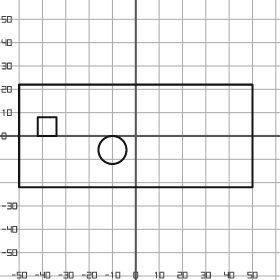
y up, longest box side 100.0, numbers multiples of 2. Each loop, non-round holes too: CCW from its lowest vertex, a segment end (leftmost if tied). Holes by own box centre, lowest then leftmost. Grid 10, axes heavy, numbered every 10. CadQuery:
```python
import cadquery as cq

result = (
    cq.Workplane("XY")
    .moveTo(-50.0, -22.0)
    .lineTo(50.0, -22.0)
    .lineTo(50.0, 22.0)
    .lineTo(-50.0, 22.0)
    .close()
    .moveTo(-10.0, -6.0)
    .circle(6.0)
    .moveTo(-42.0, 0.0)
    .lineTo(-34.0, 0.0)
    .lineTo(-34.0, 8.0)
    .lineTo(-42.0, 8.0)
    .close()
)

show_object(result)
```